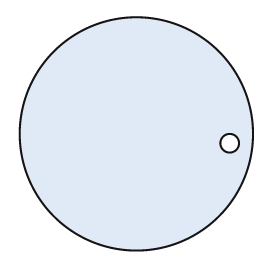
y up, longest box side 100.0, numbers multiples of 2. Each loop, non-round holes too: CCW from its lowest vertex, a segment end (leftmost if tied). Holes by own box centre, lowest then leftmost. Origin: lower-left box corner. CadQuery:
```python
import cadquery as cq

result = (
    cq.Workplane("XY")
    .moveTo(50.0, 50.0)
    .circle(50.0)
    .moveTo(90.0, 46.0)
    .circle(4.0)
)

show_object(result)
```